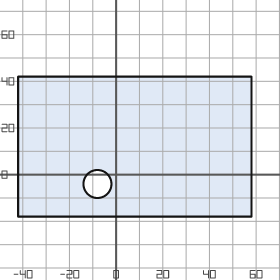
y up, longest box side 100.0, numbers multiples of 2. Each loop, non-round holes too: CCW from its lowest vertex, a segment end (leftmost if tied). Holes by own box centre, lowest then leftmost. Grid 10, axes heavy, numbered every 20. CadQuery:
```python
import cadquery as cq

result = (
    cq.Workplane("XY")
    .moveTo(-42.0, -18.0)
    .lineTo(58.0, -18.0)
    .lineTo(58.0, 42.0)
    .lineTo(-42.0, 42.0)
    .close()
    .moveTo(-8.0, -4.0)
    .circle(6.0)
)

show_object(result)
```